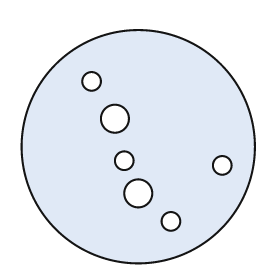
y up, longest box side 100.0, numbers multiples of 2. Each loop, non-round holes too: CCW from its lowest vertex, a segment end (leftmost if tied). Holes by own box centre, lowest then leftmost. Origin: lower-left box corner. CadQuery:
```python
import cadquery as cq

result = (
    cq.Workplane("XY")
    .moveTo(50.0, 50.0)
    .circle(50.0)
    .moveTo(64.0, 18.0)
    .circle(4.0)
    .moveTo(50.0, 30.0)
    .circle(6.0)
    .moveTo(86.0, 42.0)
    .circle(4.0)
    .moveTo(44.0, 44.0)
    .circle(4.0)
    .moveTo(40.0, 62.0)
    .circle(6.0)
    .moveTo(30.0, 78.0)
    .circle(4.0)
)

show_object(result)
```